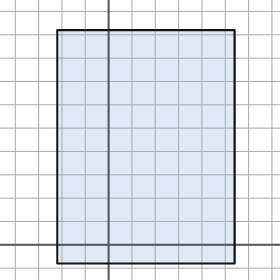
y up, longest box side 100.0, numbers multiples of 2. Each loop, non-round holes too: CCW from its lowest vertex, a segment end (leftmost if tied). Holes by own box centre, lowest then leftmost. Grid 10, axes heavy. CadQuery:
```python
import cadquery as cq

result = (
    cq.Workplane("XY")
    .moveTo(-22.0, -8.0)
    .lineTo(54.0, -8.0)
    .lineTo(54.0, 92.0)
    .lineTo(-22.0, 92.0)
    .close()
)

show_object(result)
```